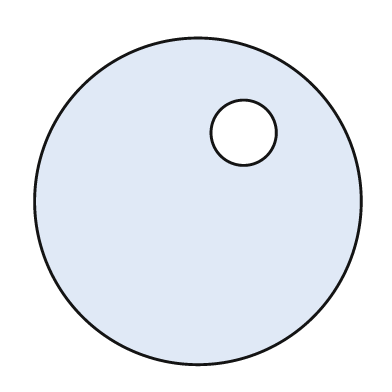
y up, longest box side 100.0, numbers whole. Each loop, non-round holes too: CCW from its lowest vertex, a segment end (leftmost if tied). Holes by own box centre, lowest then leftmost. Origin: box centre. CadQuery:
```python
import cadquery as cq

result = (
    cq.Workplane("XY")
    .moveTo(0.0, 0.0)
    .circle(50.0)
    .moveTo(14.0, 21.0)
    .circle(10.0)
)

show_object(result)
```